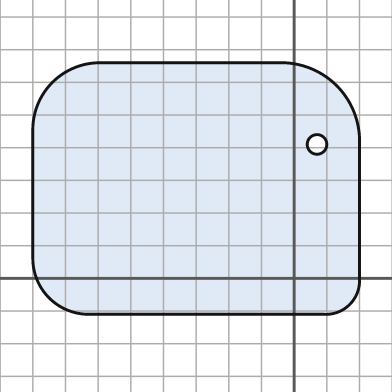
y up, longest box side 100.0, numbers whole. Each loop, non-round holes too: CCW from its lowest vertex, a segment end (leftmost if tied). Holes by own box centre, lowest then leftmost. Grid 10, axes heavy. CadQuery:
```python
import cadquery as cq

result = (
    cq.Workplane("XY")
    .moveTo(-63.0, -11.0)
    .lineTo(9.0, -11.0)
    .threePointArc((17.0, -8.0), (20.0, 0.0))
    .lineTo(20.0, 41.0)
    .threePointArc((13.0, 59.0), (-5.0, 66.0))
    .lineTo(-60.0, 66.0)
    .threePointArc((-74.0, 60.0), (-80.0, 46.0))
    .lineTo(-80.0, 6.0)
    .threePointArc((-75.0, -6.0), (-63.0, -11.0))
    .close()
    .moveTo(7.0, 41.0)
    .circle(3.0)
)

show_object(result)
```